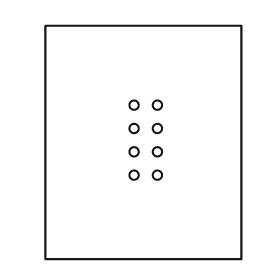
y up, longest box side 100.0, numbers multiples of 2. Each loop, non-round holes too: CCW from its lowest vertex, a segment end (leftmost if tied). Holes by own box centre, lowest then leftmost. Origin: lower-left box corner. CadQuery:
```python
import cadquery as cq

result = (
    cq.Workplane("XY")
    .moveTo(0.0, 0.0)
    .lineTo(84.0, 0.0)
    .lineTo(84.0, 100.0)
    .lineTo(0.0, 100.0)
    .close()
    .moveTo(38.0, 36.0)
    .circle(2.0)
    .moveTo(48.0, 36.0)
    .circle(2.0)
    .moveTo(38.0, 46.0)
    .circle(2.0)
    .moveTo(48.0, 46.0)
    .circle(2.0)
    .moveTo(38.0, 56.0)
    .circle(2.0)
    .moveTo(48.0, 56.0)
    .circle(2.0)
    .moveTo(38.0, 66.0)
    .circle(2.0)
    .moveTo(48.0, 66.0)
    .circle(2.0)
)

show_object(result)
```